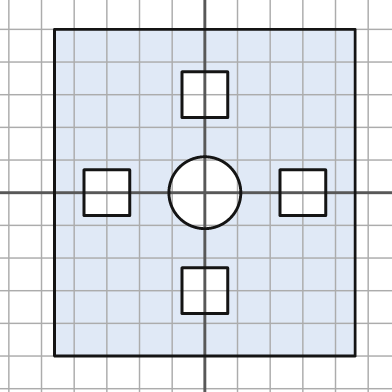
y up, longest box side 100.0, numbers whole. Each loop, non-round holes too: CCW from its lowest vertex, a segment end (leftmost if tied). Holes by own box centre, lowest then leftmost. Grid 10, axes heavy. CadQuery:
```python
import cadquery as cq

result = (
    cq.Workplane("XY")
    .moveTo(-46.0, -50.0)
    .lineTo(46.0, -50.0)
    .lineTo(46.0, 50.0)
    .lineTo(-46.0, 50.0)
    .close()
    .moveTo(-7.0, -37.0)
    .lineTo(7.0, -37.0)
    .lineTo(7.0, -23.0)
    .lineTo(-7.0, -23.0)
    .close()
    .moveTo(-37.0, -7.0)
    .lineTo(-23.0, -7.0)
    .lineTo(-23.0, 7.0)
    .lineTo(-37.0, 7.0)
    .close()
    .moveTo(0.0, 0.0)
    .circle(11.0)
    .moveTo(23.0, -7.0)
    .lineTo(37.0, -7.0)
    .lineTo(37.0, 7.0)
    .lineTo(23.0, 7.0)
    .close()
    .moveTo(-7.0, 23.0)
    .lineTo(7.0, 23.0)
    .lineTo(7.0, 37.0)
    .lineTo(-7.0, 37.0)
    .close()
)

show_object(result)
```